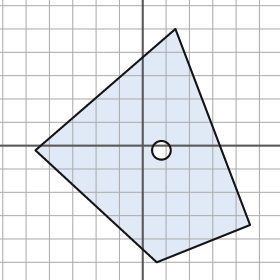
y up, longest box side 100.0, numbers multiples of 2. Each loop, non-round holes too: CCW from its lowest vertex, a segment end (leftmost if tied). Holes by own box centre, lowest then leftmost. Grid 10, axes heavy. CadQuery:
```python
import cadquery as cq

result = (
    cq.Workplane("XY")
    .moveTo(6.0, -50.0)
    .lineTo(46.0, -34.0)
    .lineTo(14.0, 50.0)
    .lineTo(-46.0, -2.0)
    .close()
    .moveTo(8.0, -2.0)
    .circle(4.0)
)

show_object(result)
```